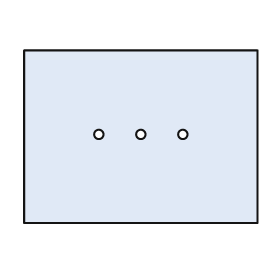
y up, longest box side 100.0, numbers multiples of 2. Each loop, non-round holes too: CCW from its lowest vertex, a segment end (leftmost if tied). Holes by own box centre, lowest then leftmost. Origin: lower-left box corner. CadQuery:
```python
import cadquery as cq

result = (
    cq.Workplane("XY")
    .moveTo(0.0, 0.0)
    .lineTo(100.0, 0.0)
    .lineTo(100.0, 74.0)
    .lineTo(0.0, 74.0)
    .close()
    .moveTo(32.0, 38.0)
    .circle(2.0)
    .moveTo(50.0, 38.0)
    .circle(2.0)
    .moveTo(68.0, 38.0)
    .circle(2.0)
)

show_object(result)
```